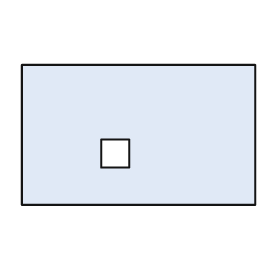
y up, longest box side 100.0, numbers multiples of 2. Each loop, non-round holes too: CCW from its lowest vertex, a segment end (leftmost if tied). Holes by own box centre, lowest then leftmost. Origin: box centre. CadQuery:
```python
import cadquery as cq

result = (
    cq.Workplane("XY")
    .moveTo(-50.0, -30.0)
    .lineTo(50.0, -30.0)
    .lineTo(50.0, 30.0)
    .lineTo(-50.0, 30.0)
    .close()
    .moveTo(-16.0, -14.0)
    .lineTo(-4.0, -14.0)
    .lineTo(-4.0, -2.0)
    .lineTo(-16.0, -2.0)
    .close()
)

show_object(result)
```